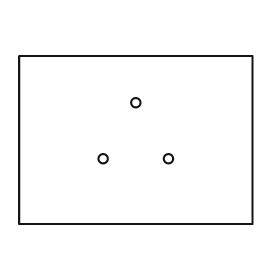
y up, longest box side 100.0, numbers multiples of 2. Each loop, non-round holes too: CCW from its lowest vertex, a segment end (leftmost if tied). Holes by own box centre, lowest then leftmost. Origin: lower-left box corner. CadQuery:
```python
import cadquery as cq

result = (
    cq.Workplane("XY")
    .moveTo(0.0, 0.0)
    .lineTo(100.0, 0.0)
    .lineTo(100.0, 72.0)
    .lineTo(0.0, 72.0)
    .close()
    .moveTo(36.0, 28.0)
    .circle(2.0)
    .moveTo(64.0, 28.0)
    .circle(2.0)
    .moveTo(50.0, 52.0)
    .circle(2.0)
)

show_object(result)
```